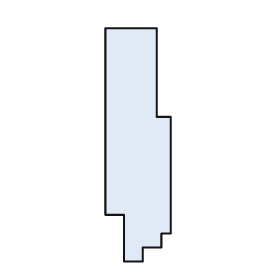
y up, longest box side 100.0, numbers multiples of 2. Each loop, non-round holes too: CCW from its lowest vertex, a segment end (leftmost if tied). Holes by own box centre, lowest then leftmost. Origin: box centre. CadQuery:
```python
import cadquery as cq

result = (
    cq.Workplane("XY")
    .moveTo(-6.0, -50.0)
    .lineTo(2.0, -50.0)
    .lineTo(2.0, -44.0)
    .lineTo(10.0, -44.0)
    .lineTo(10.0, -38.0)
    .lineTo(14.0, -38.0)
    .lineTo(14.0, 12.0)
    .lineTo(8.0, 12.0)
    .lineTo(8.0, 50.0)
    .lineTo(-14.0, 50.0)
    .lineTo(-14.0, -30.0)
    .lineTo(-6.0, -30.0)
    .close()
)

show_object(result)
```